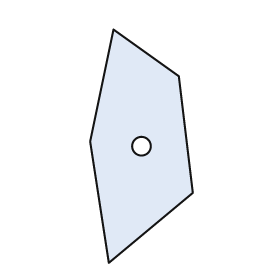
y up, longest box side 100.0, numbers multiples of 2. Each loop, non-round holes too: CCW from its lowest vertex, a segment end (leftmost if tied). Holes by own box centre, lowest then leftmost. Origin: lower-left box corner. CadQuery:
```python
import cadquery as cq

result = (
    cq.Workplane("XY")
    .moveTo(8.0, 0.0)
    .lineTo(44.0, 30.0)
    .lineTo(38.0, 80.0)
    .lineTo(10.0, 100.0)
    .lineTo(0.0, 52.0)
    .close()
    .moveTo(22.0, 50.0)
    .circle(4.0)
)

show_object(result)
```